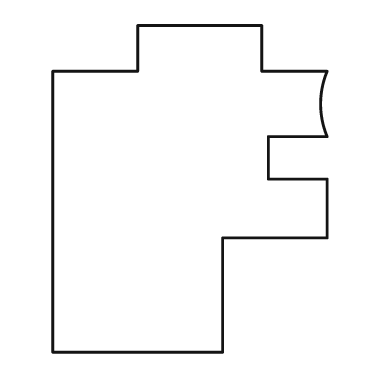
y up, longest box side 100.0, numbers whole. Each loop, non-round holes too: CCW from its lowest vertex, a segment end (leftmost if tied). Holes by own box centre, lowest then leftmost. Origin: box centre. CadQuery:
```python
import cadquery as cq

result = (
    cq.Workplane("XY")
    .moveTo(-42.0, -50.0)
    .lineTo(10.0, -50.0)
    .lineTo(10.0, -15.0)
    .lineTo(42.0, -15.0)
    .lineTo(42.0, 3.0)
    .lineTo(24.0, 3.0)
    .lineTo(24.0, 16.0)
    .lineTo(42.0, 16.0)
    .threePointArc((40.0, 26.0), (42.0, 36.0))
    .lineTo(22.0, 36.0)
    .lineTo(22.0, 50.0)
    .lineTo(-16.0, 50.0)
    .lineTo(-16.0, 36.0)
    .lineTo(-42.0, 36.0)
    .close()
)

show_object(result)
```